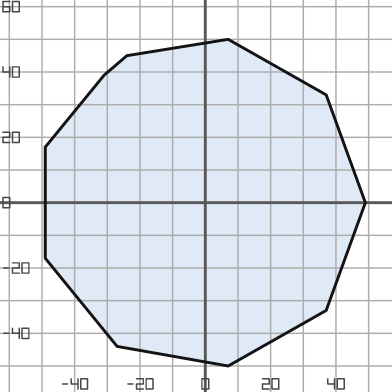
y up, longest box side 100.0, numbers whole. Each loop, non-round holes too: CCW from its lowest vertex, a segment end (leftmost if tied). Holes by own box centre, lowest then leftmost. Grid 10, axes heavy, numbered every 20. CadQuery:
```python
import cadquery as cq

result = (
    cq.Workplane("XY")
    .moveTo(7.0, -50.0)
    .lineTo(37.0, -33.0)
    .lineTo(49.0, 0.0)
    .lineTo(37.0, 33.0)
    .lineTo(7.0, 50.0)
    .lineTo(-24.0, 45.0)
    .lineTo(-31.0, 39.0)
    .lineTo(-49.0, 17.0)
    .lineTo(-49.0, -17.0)
    .lineTo(-27.0, -44.0)
    .close()
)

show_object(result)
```